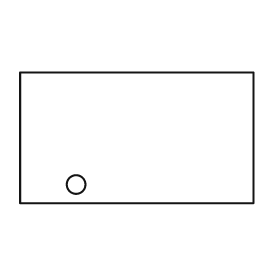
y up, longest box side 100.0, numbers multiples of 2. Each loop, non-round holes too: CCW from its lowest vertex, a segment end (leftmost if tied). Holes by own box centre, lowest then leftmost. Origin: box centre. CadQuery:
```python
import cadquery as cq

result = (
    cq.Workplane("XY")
    .moveTo(-50.0, -28.0)
    .lineTo(50.0, -28.0)
    .lineTo(50.0, 28.0)
    .lineTo(-50.0, 28.0)
    .close()
    .moveTo(-26.0, -20.0)
    .circle(4.0)
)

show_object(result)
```